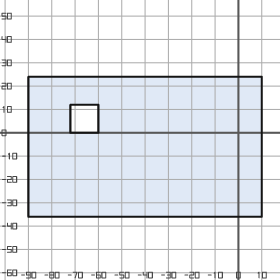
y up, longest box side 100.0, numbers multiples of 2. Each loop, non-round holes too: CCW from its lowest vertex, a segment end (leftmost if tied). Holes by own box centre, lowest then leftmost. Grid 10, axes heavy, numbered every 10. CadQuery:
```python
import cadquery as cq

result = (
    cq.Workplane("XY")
    .moveTo(-90.0, -36.0)
    .lineTo(10.0, -36.0)
    .lineTo(10.0, 24.0)
    .lineTo(-90.0, 24.0)
    .close()
    .moveTo(-72.0, 0.0)
    .lineTo(-60.0, 0.0)
    .lineTo(-60.0, 12.0)
    .lineTo(-72.0, 12.0)
    .close()
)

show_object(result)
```